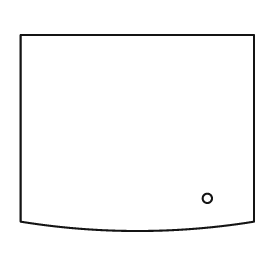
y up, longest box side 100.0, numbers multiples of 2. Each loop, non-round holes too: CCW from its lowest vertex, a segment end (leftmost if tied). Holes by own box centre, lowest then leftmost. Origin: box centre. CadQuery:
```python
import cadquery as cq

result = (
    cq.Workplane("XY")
    .moveTo(-50.0, -38.0)
    .threePointArc((0.0, -42.0), (50.0, -38.0))
    .lineTo(50.0, 42.0)
    .lineTo(-50.0, 42.0)
    .close()
    .moveTo(30.0, -28.0)
    .circle(2.0)
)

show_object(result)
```